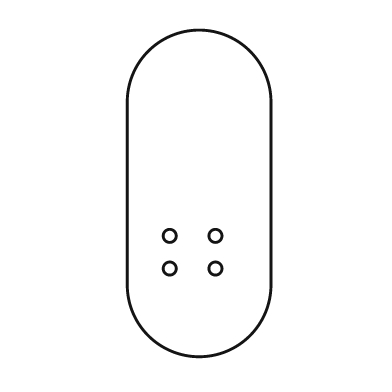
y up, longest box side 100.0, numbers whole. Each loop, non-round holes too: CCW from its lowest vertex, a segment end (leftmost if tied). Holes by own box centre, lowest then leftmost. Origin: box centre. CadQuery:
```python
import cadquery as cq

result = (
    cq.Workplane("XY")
    .moveTo(-22.0, -28.0)
    .threePointArc((0.0, -50.0), (22.0, -28.0))
    .lineTo(22.0, 28.0)
    .threePointArc((0.0, 50.0), (-22.0, 28.0))
    .close()
    .moveTo(-9.0, -23.0)
    .circle(2.0)
    .moveTo(5.0, -23.0)
    .circle(2.0)
    .moveTo(-9.0, -13.0)
    .circle(2.0)
    .moveTo(5.0, -13.0)
    .circle(2.0)
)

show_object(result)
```